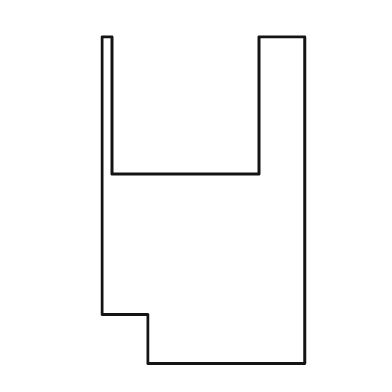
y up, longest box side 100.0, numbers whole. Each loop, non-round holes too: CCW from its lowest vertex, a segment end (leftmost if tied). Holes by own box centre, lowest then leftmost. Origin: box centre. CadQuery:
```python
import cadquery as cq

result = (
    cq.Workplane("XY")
    .moveTo(-17.0, -50.0)
    .lineTo(31.0, -50.0)
    .lineTo(31.0, 50.0)
    .lineTo(17.0, 50.0)
    .lineTo(17.0, 8.0)
    .lineTo(-28.0, 8.0)
    .lineTo(-28.0, 50.0)
    .lineTo(-31.0, 50.0)
    .lineTo(-31.0, -35.0)
    .lineTo(-17.0, -35.0)
    .close()
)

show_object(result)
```